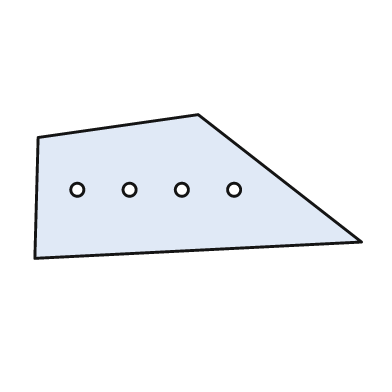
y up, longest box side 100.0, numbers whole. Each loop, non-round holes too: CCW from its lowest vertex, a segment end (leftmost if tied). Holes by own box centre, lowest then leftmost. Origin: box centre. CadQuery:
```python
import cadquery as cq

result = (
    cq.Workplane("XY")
    .moveTo(-50.0, -22.0)
    .lineTo(50.0, -17.0)
    .lineTo(0.0, 22.0)
    .lineTo(-49.0, 15.0)
    .close()
    .moveTo(-37.0, -1.0)
    .circle(2.0)
    .moveTo(-21.0, -1.0)
    .circle(2.0)
    .moveTo(-5.0, -1.0)
    .circle(2.0)
    .moveTo(11.0, -1.0)
    .circle(2.0)
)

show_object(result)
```